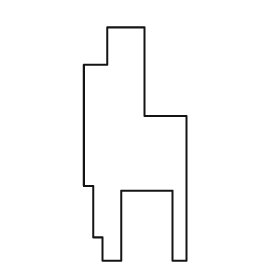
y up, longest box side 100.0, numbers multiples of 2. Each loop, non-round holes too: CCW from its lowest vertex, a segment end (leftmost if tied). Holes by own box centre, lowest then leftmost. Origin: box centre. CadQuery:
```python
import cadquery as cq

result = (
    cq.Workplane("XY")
    .moveTo(-14.0, -50.0)
    .lineTo(-6.0, -50.0)
    .lineTo(-6.0, -20.0)
    .lineTo(16.0, -20.0)
    .lineTo(16.0, -50.0)
    .lineTo(22.0, -50.0)
    .lineTo(22.0, 12.0)
    .lineTo(4.0, 12.0)
    .lineTo(4.0, 50.0)
    .lineTo(-12.0, 50.0)
    .lineTo(-12.0, 34.0)
    .lineTo(-22.0, 34.0)
    .lineTo(-22.0, -18.0)
    .lineTo(-18.0, -18.0)
    .lineTo(-18.0, -40.0)
    .lineTo(-14.0, -40.0)
    .close()
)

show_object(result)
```